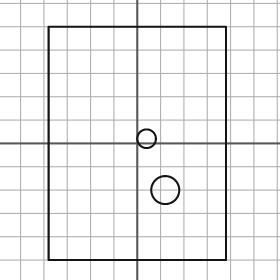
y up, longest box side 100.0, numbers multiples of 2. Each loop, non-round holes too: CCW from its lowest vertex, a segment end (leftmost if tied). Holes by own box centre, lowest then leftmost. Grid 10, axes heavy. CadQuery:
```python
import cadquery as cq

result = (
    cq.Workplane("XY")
    .moveTo(-38.0, -50.0)
    .lineTo(38.0, -50.0)
    .lineTo(38.0, 50.0)
    .lineTo(-38.0, 50.0)
    .close()
    .moveTo(12.0, -20.0)
    .circle(6.0)
    .moveTo(4.0, 2.0)
    .circle(4.0)
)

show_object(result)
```